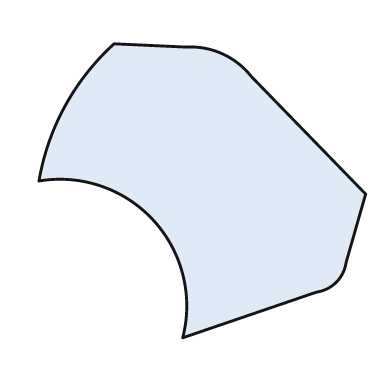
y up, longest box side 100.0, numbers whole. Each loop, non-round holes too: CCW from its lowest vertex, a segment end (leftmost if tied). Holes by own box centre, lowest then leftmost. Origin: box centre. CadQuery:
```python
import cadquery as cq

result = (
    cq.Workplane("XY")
    .moveTo(-6.0, -45.0)
    .lineTo(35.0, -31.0)
    .threePointArc((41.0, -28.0), (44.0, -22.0))
    .lineTo(50.0, -1.0)
    .lineTo(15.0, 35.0)
    .threePointArc((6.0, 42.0), (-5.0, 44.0))
    .lineTo(-27.0, 45.0)
    .threePointArc((-42.0, 26.0), (-50.0, 3.0))
    .threePointArc((-15.0, -9.0), (-6.0, -45.0))
    .close()
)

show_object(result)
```